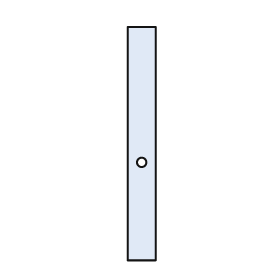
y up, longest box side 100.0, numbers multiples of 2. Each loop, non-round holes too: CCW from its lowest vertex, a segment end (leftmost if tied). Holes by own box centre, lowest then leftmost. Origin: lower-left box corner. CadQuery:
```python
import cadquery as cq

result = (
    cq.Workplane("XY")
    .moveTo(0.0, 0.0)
    .lineTo(12.0, 0.0)
    .lineTo(12.0, 100.0)
    .lineTo(0.0, 100.0)
    .close()
    .moveTo(6.0, 42.0)
    .circle(2.0)
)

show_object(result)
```